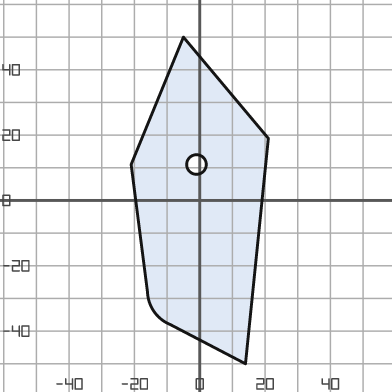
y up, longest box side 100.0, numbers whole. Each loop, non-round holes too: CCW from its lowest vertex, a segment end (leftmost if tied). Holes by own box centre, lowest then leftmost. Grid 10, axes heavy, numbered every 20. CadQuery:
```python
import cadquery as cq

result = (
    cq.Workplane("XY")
    .moveTo(14.0, -50.0)
    .lineTo(21.0, 19.0)
    .lineTo(-5.0, 50.0)
    .lineTo(-21.0, 11.0)
    .lineTo(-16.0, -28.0)
    .threePointArc((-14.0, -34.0), (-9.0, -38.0))
    .close()
    .moveTo(-1.0, 11.0)
    .circle(3.0)
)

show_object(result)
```